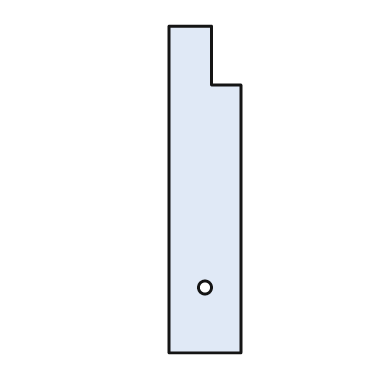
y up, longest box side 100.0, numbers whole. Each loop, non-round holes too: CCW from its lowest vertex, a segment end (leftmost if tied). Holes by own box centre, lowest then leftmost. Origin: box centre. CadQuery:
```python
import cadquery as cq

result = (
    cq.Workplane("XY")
    .moveTo(-11.0, -50.0)
    .lineTo(11.0, -50.0)
    .lineTo(11.0, 32.0)
    .lineTo(2.0, 32.0)
    .lineTo(2.0, 50.0)
    .lineTo(-11.0, 50.0)
    .close()
    .moveTo(0.0, -30.0)
    .circle(2.0)
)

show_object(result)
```